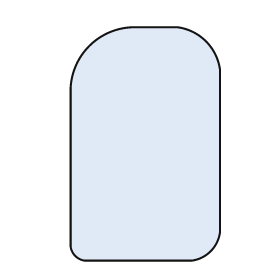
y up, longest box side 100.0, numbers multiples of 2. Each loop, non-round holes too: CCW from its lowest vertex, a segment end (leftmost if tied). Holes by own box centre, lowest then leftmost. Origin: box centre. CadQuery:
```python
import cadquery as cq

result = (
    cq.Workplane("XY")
    .moveTo(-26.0, -50.0)
    .lineTo(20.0, -50.0)
    .threePointArc((28.0, -46.0), (32.0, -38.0))
    .lineTo(32.0, 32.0)
    .threePointArc((26.0, 44.0), (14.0, 50.0))
    .lineTo(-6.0, 50.0)
    .threePointArc((-24.0, 42.0), (-32.0, 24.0))
    .lineTo(-32.0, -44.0)
    .threePointArc((-30.0, -48.0), (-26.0, -50.0))
    .close()
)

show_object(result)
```